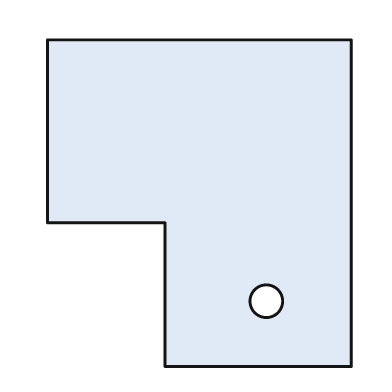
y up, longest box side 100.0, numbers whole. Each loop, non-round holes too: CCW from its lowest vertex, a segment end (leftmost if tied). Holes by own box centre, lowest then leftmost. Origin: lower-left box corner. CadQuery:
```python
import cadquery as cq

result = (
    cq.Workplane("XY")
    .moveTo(36.0, 0.0)
    .lineTo(93.0, 0.0)
    .lineTo(93.0, 100.0)
    .lineTo(0.0, 100.0)
    .lineTo(0.0, 44.0)
    .lineTo(36.0, 44.0)
    .close()
    .moveTo(67.0, 20.0)
    .circle(5.0)
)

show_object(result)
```